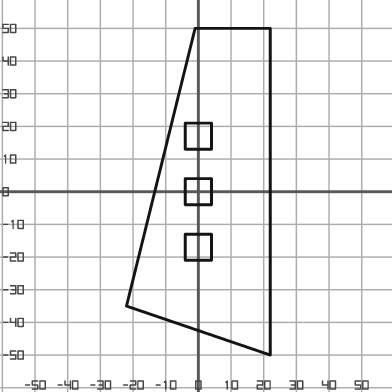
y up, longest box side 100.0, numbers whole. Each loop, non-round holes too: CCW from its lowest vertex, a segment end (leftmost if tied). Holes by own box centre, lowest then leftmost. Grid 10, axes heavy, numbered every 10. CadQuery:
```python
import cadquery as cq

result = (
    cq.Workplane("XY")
    .moveTo(22.0, -50.0)
    .lineTo(22.0, 50.0)
    .lineTo(-1.0, 50.0)
    .lineTo(-22.0, -35.0)
    .close()
    .moveTo(-4.0, -21.0)
    .lineTo(4.0, -21.0)
    .lineTo(4.0, -13.0)
    .lineTo(-4.0, -13.0)
    .close()
    .moveTo(-4.0, -4.0)
    .lineTo(4.0, -4.0)
    .lineTo(4.0, 4.0)
    .lineTo(-4.0, 4.0)
    .close()
    .moveTo(-4.0, 13.0)
    .lineTo(4.0, 13.0)
    .lineTo(4.0, 21.0)
    .lineTo(-4.0, 21.0)
    .close()
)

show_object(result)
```